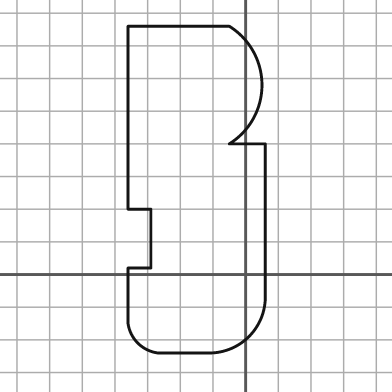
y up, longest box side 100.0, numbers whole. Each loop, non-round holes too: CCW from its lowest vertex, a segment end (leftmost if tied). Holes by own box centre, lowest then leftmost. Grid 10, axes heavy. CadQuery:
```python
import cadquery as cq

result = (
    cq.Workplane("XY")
    .moveTo(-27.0, -24.0)
    .lineTo(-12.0, -24.0)
    .threePointArc((1.0, -19.0), (6.0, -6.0))
    .lineTo(6.0, 40.0)
    .lineTo(-5.0, 40.0)
    .threePointArc((5.0, 58.0), (-5.0, 76.0))
    .lineTo(-36.0, 76.0)
    .lineTo(-36.0, 20.0)
    .lineTo(-29.0, 20.0)
    .lineTo(-29.0, 2.0)
    .lineTo(-36.0, 2.0)
    .lineTo(-36.0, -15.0)
    .threePointArc((-33.0, -21.0), (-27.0, -24.0))
    .close()
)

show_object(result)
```